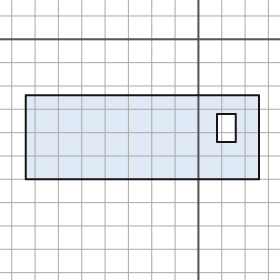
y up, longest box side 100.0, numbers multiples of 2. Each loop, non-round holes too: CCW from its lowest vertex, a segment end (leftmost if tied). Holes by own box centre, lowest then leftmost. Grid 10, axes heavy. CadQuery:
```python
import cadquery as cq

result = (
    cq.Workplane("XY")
    .moveTo(-74.0, -60.0)
    .lineTo(26.0, -60.0)
    .lineTo(26.0, -24.0)
    .lineTo(-74.0, -24.0)
    .close()
    .moveTo(8.0, -44.0)
    .lineTo(16.0, -44.0)
    .lineTo(16.0, -32.0)
    .lineTo(8.0, -32.0)
    .close()
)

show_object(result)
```